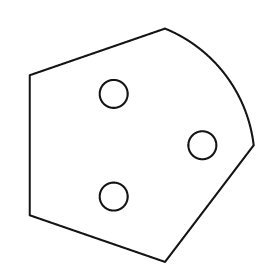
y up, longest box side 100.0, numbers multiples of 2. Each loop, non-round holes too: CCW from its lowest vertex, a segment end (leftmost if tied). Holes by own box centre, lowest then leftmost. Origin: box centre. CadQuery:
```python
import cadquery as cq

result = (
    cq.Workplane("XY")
    .moveTo(10.0, -50.0)
    .lineTo(48.0, 0.0)
    .threePointArc((36.0, 30.0), (10.0, 50.0))
    .lineTo(-48.0, 30.0)
    .lineTo(-48.0, -30.0)
    .close()
    .moveTo(-12.0, -22.0)
    .circle(6.0)
    .moveTo(26.0, 0.0)
    .circle(6.0)
    .moveTo(-12.0, 22.0)
    .circle(6.0)
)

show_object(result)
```